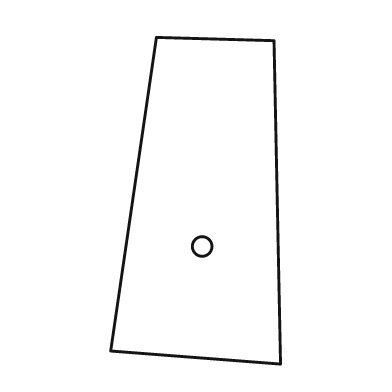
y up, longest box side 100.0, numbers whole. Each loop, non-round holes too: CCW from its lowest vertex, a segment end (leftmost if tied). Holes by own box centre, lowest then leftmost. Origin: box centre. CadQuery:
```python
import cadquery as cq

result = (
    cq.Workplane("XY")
    .moveTo(26.0, -50.0)
    .lineTo(24.0, 49.0)
    .lineTo(-12.0, 50.0)
    .lineTo(-26.0, -46.0)
    .close()
    .moveTo(2.0, -14.0)
    .circle(3.0)
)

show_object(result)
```